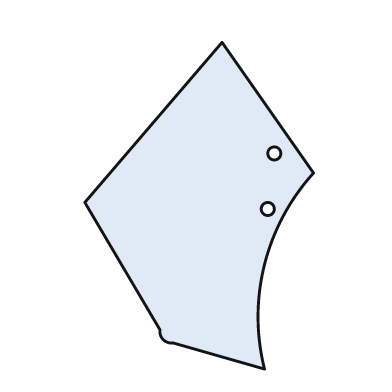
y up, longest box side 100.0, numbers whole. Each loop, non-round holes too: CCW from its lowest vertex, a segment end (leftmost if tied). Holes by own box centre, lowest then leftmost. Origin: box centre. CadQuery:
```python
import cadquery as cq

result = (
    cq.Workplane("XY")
    .moveTo(20.0, -50.0)
    .threePointArc((20.0, -18.0), (35.0, 10.0))
    .lineTo(7.0, 50.0)
    .lineTo(-35.0, 1.0)
    .lineTo(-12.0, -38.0)
    .threePointArc((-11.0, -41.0), (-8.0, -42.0))
    .close()
    .moveTo(21.0, -1.0)
    .circle(2.0)
    .moveTo(23.0, 16.0)
    .circle(2.0)
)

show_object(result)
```